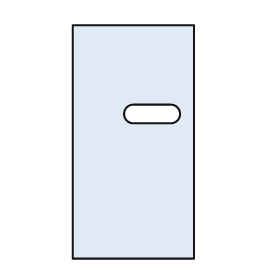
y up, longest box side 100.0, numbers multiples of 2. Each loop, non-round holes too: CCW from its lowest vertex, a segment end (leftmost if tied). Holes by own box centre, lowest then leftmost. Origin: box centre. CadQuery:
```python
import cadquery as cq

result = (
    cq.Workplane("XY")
    .moveTo(-26.0, -50.0)
    .lineTo(26.0, -50.0)
    .lineTo(26.0, 50.0)
    .lineTo(-26.0, 50.0)
    .close()
    .moveTo(0.0, 8.0)
    .lineTo(16.0, 8.0)
    .threePointArc((20.0, 12.0), (16.0, 16.0))
    .lineTo(0.0, 16.0)
    .threePointArc((-4.0, 12.0), (0.0, 8.0))
    .close()
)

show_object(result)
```